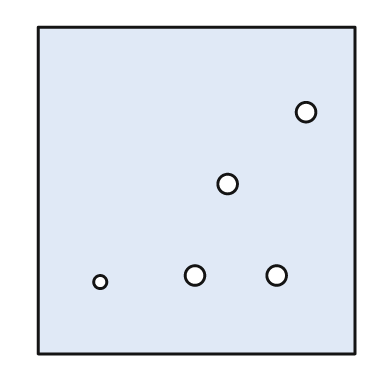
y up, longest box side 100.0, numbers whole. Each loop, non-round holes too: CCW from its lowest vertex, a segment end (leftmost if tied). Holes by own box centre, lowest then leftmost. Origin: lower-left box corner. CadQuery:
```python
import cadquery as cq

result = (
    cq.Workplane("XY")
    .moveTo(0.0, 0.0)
    .lineTo(97.0, 0.0)
    .lineTo(97.0, 100.0)
    .lineTo(0.0, 100.0)
    .close()
    .moveTo(19.0, 22.0)
    .circle(2.0)
    .moveTo(48.0, 24.0)
    .circle(3.0)
    .moveTo(73.0, 24.0)
    .circle(3.0)
    .moveTo(58.0, 52.0)
    .circle(3.0)
    .moveTo(82.0, 74.0)
    .circle(3.0)
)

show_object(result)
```